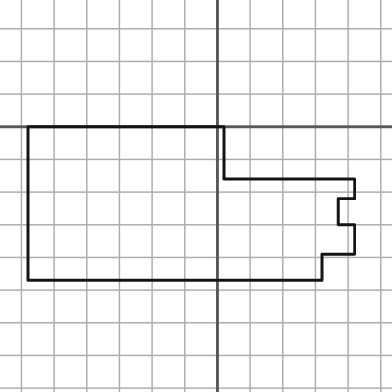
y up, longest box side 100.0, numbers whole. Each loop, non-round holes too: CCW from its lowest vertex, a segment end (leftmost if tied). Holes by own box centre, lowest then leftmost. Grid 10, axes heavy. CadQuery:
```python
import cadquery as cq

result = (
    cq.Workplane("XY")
    .moveTo(-58.0, -47.0)
    .lineTo(32.0, -47.0)
    .lineTo(32.0, -39.0)
    .lineTo(42.0, -39.0)
    .lineTo(42.0, -30.0)
    .lineTo(37.0, -30.0)
    .lineTo(37.0, -22.0)
    .lineTo(42.0, -22.0)
    .lineTo(42.0, -16.0)
    .lineTo(2.0, -16.0)
    .lineTo(2.0, 0.0)
    .lineTo(-58.0, 0.0)
    .close()
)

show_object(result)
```